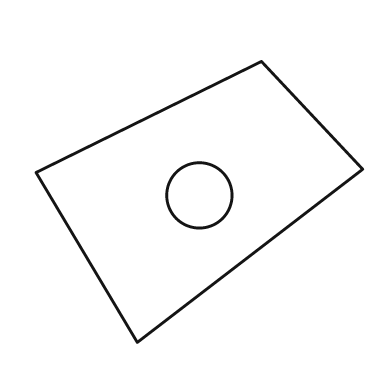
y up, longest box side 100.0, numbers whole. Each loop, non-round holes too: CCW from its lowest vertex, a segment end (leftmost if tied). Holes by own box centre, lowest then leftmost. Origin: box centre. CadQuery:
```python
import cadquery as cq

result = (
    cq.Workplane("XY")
    .moveTo(-19.0, -43.0)
    .lineTo(50.0, 10.0)
    .lineTo(19.0, 43.0)
    .lineTo(-50.0, 9.0)
    .close()
    .moveTo(0.0, 2.0)
    .circle(10.0)
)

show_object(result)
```